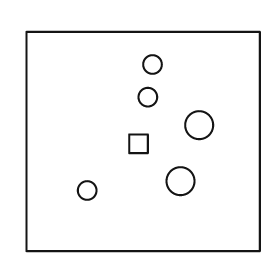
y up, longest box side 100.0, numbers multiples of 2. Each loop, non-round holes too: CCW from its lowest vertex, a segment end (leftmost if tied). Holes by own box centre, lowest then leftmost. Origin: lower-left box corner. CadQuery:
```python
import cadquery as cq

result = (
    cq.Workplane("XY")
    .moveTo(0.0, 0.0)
    .lineTo(100.0, 0.0)
    .lineTo(100.0, 94.0)
    .lineTo(0.0, 94.0)
    .close()
    .moveTo(26.0, 26.0)
    .circle(4.0)
    .moveTo(66.0, 30.0)
    .circle(6.0)
    .moveTo(44.0, 42.0)
    .lineTo(52.0, 42.0)
    .lineTo(52.0, 50.0)
    .lineTo(44.0, 50.0)
    .close()
    .moveTo(74.0, 54.0)
    .circle(6.0)
    .moveTo(52.0, 66.0)
    .circle(4.0)
    .moveTo(54.0, 80.0)
    .circle(4.0)
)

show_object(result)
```